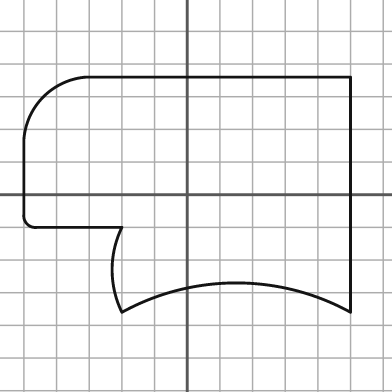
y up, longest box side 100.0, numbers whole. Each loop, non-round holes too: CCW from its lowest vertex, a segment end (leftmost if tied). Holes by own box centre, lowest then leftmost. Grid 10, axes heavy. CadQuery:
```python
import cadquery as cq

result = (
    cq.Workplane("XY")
    .moveTo(-20.0, -36.0)
    .threePointArc((15.0, -27.0), (50.0, -36.0))
    .lineTo(50.0, 36.0)
    .lineTo(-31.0, 36.0)
    .threePointArc((-44.0, 30.0), (-50.0, 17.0))
    .lineTo(-50.0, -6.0)
    .threePointArc((-49.0, -9.0), (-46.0, -10.0))
    .lineTo(-20.0, -10.0)
    .threePointArc((-23.0, -23.0), (-20.0, -36.0))
    .close()
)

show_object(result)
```